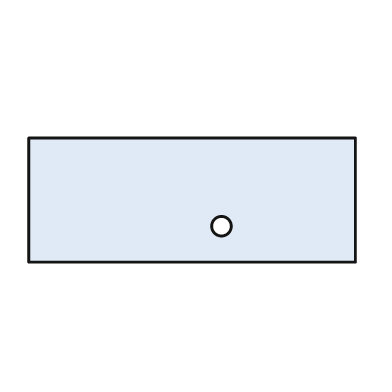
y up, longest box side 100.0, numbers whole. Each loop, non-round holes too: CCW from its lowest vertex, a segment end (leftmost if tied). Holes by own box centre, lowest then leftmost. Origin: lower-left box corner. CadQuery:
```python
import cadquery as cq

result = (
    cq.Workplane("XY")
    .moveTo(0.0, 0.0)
    .lineTo(100.0, 0.0)
    .lineTo(100.0, 38.0)
    .lineTo(0.0, 38.0)
    .close()
    .moveTo(59.0, 11.0)
    .circle(3.0)
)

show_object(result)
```